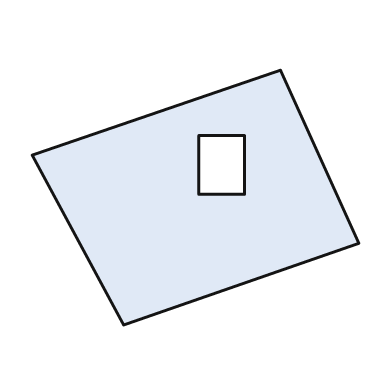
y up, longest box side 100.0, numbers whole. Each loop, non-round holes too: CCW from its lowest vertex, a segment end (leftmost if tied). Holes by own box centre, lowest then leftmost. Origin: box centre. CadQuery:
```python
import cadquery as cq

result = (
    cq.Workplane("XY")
    .moveTo(-22.0, -39.0)
    .lineTo(50.0, -14.0)
    .lineTo(26.0, 39.0)
    .lineTo(-50.0, 13.0)
    .close()
    .moveTo(1.0, 1.0)
    .lineTo(15.0, 1.0)
    .lineTo(15.0, 19.0)
    .lineTo(1.0, 19.0)
    .close()
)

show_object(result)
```